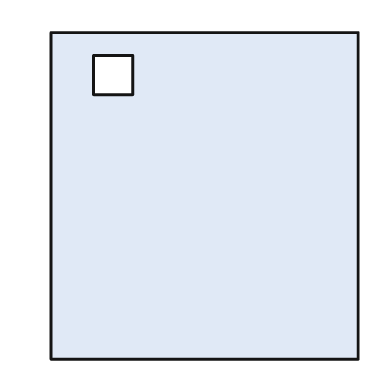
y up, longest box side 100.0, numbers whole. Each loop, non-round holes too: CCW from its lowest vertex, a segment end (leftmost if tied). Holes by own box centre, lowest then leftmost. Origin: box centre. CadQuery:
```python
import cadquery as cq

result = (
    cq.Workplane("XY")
    .moveTo(-47.0, -50.0)
    .lineTo(47.0, -50.0)
    .lineTo(47.0, 50.0)
    .lineTo(-47.0, 50.0)
    .close()
    .moveTo(-34.0, 31.0)
    .lineTo(-22.0, 31.0)
    .lineTo(-22.0, 43.0)
    .lineTo(-34.0, 43.0)
    .close()
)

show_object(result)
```